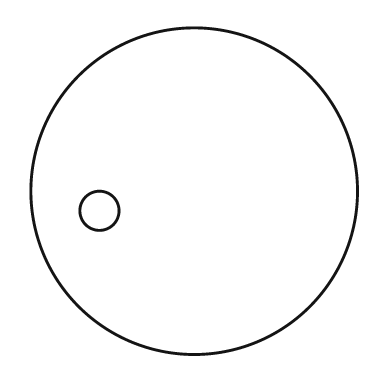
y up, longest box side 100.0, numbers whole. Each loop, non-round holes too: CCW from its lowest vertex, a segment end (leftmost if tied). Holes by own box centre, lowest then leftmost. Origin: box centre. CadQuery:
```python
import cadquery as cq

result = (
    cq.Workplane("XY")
    .moveTo(0.0, 0.0)
    .circle(50.0)
    .moveTo(-29.0, -6.0)
    .circle(6.0)
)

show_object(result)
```